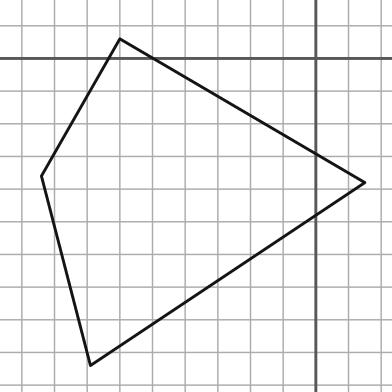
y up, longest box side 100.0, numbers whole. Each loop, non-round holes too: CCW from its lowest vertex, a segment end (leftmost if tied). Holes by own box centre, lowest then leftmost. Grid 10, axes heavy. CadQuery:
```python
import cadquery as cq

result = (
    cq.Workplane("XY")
    .moveTo(-69.0, -94.0)
    .lineTo(15.0, -38.0)
    .lineTo(-60.0, 6.0)
    .lineTo(-84.0, -36.0)
    .close()
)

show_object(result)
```